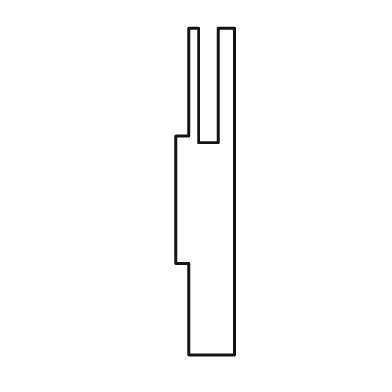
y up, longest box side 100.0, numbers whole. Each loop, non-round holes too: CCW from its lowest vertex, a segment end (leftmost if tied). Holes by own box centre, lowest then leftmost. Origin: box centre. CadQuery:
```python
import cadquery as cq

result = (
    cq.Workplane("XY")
    .moveTo(-5.0, -50.0)
    .lineTo(9.0, -50.0)
    .lineTo(9.0, 50.0)
    .lineTo(4.0, 50.0)
    .lineTo(4.0, 15.0)
    .lineTo(-2.0, 15.0)
    .lineTo(-2.0, 50.0)
    .lineTo(-5.0, 50.0)
    .lineTo(-5.0, 17.0)
    .lineTo(-9.0, 17.0)
    .lineTo(-9.0, -22.0)
    .lineTo(-5.0, -22.0)
    .close()
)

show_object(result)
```